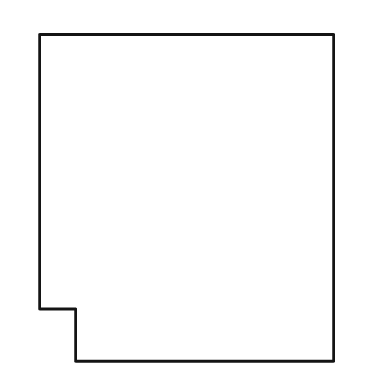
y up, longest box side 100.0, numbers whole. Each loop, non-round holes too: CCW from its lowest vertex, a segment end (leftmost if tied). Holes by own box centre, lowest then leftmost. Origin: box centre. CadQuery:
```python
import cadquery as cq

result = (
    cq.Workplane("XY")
    .moveTo(-34.0, -50.0)
    .lineTo(45.0, -50.0)
    .lineTo(45.0, 50.0)
    .lineTo(-45.0, 50.0)
    .lineTo(-45.0, -34.0)
    .lineTo(-34.0, -34.0)
    .close()
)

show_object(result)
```